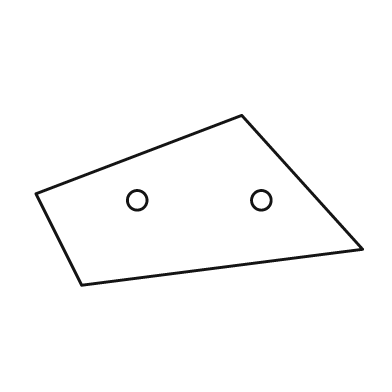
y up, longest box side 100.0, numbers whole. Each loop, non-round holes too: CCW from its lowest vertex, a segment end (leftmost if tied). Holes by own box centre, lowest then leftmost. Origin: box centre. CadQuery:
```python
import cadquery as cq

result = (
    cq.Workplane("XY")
    .moveTo(-36.0, -26.0)
    .lineTo(50.0, -15.0)
    .lineTo(13.0, 26.0)
    .lineTo(-50.0, 2.0)
    .close()
    .moveTo(-19.0, 0.0)
    .circle(3.0)
    .moveTo(19.0, 0.0)
    .circle(3.0)
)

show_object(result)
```